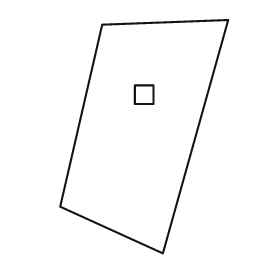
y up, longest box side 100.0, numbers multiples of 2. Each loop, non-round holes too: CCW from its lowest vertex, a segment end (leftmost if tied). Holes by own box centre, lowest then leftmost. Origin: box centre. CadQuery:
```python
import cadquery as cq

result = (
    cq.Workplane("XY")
    .moveTo(8.0, -50.0)
    .lineTo(36.0, 50.0)
    .lineTo(-18.0, 48.0)
    .lineTo(-36.0, -30.0)
    .close()
    .moveTo(-4.0, 14.0)
    .lineTo(4.0, 14.0)
    .lineTo(4.0, 22.0)
    .lineTo(-4.0, 22.0)
    .close()
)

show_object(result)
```